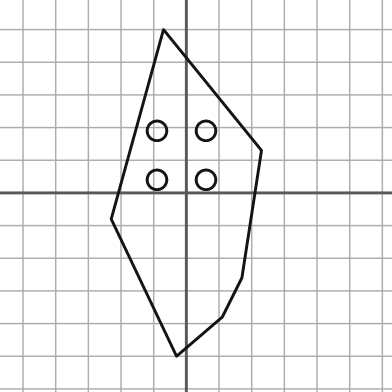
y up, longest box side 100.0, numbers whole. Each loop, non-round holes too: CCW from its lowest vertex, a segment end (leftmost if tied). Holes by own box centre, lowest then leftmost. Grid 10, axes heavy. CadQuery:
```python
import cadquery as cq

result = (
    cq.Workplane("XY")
    .moveTo(-3.0, -50.0)
    .lineTo(11.0, -38.0)
    .lineTo(17.0, -26.0)
    .lineTo(23.0, 13.0)
    .lineTo(-7.0, 50.0)
    .lineTo(-23.0, -8.0)
    .close()
    .moveTo(-9.0, 4.0)
    .circle(3.0)
    .moveTo(6.0, 4.0)
    .circle(3.0)
    .moveTo(-9.0, 19.0)
    .circle(3.0)
    .moveTo(6.0, 19.0)
    .circle(3.0)
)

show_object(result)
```